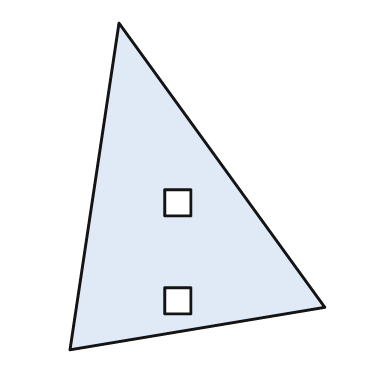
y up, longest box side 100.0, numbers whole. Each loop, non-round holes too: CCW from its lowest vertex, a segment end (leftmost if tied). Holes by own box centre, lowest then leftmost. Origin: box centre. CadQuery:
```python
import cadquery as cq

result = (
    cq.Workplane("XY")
    .moveTo(-39.0, -50.0)
    .lineTo(39.0, -37.0)
    .lineTo(-24.0, 50.0)
    .close()
    .moveTo(-10.0, -39.0)
    .lineTo(-2.0, -39.0)
    .lineTo(-2.0, -31.0)
    .lineTo(-10.0, -31.0)
    .close()
    .moveTo(-10.0, -9.0)
    .lineTo(-2.0, -9.0)
    .lineTo(-2.0, -1.0)
    .lineTo(-10.0, -1.0)
    .close()
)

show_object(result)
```